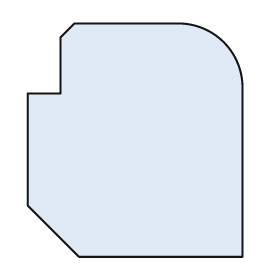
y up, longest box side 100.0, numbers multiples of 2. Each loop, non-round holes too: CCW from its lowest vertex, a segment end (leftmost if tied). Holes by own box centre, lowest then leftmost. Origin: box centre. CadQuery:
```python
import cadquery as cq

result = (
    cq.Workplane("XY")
    .moveTo(-24.0, -50.0)
    .lineTo(46.0, -50.0)
    .lineTo(46.0, 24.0)
    .threePointArc((38.0, 42.0), (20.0, 50.0))
    .lineTo(-26.0, 50.0)
    .lineTo(-32.0, 44.0)
    .lineTo(-32.0, 20.0)
    .lineTo(-46.0, 20.0)
    .lineTo(-46.0, -28.0)
    .close()
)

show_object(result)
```